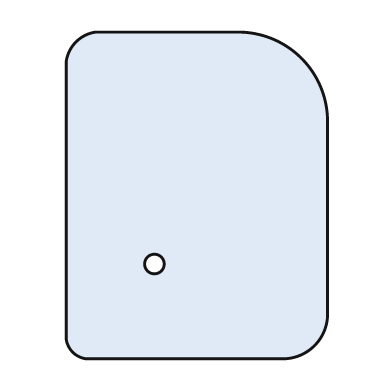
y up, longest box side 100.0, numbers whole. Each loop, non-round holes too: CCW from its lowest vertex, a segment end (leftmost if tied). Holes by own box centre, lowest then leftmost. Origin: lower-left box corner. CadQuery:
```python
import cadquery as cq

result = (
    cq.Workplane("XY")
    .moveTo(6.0, 0.0)
    .lineTo(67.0, 0.0)
    .threePointArc((76.0, 4.0), (80.0, 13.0))
    .lineTo(80.0, 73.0)
    .threePointArc((72.0, 92.0), (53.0, 100.0))
    .lineTo(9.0, 100.0)
    .threePointArc((3.0, 97.0), (0.0, 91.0))
    .lineTo(0.0, 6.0)
    .threePointArc((2.0, 2.0), (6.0, 0.0))
    .close()
    .moveTo(27.0, 29.0)
    .circle(3.0)
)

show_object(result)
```